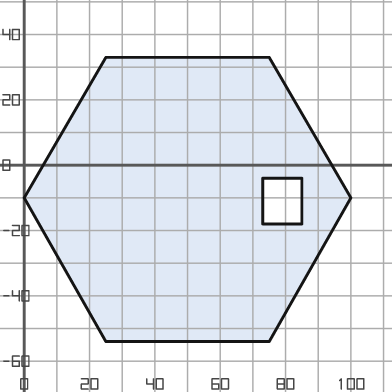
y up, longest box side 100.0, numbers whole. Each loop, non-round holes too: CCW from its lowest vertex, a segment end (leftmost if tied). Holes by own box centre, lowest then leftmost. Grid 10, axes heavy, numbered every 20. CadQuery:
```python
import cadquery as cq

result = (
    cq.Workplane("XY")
    .moveTo(25.0, -54.0)
    .lineTo(75.0, -54.0)
    .lineTo(100.0, -10.0)
    .lineTo(75.0, 33.0)
    .lineTo(25.0, 33.0)
    .lineTo(0.0, -10.0)
    .close()
    .moveTo(73.0, -18.0)
    .lineTo(85.0, -18.0)
    .lineTo(85.0, -4.0)
    .lineTo(73.0, -4.0)
    .close()
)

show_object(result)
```